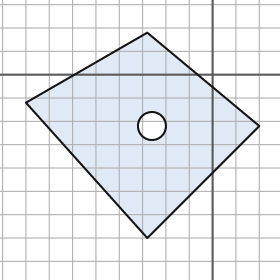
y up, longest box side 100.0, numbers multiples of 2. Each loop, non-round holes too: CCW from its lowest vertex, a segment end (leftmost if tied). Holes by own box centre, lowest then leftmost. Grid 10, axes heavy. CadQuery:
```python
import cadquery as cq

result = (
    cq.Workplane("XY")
    .moveTo(-28.0, -70.0)
    .lineTo(20.0, -22.0)
    .lineTo(-28.0, 18.0)
    .lineTo(-80.0, -12.0)
    .close()
    .moveTo(-26.0, -22.0)
    .circle(6.0)
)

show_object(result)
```